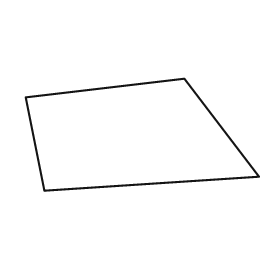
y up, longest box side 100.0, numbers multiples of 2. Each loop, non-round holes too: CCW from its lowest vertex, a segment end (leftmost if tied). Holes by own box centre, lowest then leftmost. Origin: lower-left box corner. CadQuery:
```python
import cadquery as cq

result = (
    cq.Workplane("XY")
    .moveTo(8.0, 0.0)
    .lineTo(100.0, 6.0)
    .lineTo(68.0, 48.0)
    .lineTo(0.0, 40.0)
    .close()
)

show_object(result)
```